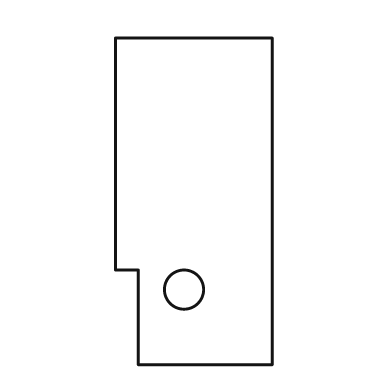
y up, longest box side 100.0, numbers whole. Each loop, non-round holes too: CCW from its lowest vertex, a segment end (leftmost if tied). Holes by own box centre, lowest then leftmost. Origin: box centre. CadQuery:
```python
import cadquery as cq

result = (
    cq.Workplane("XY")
    .moveTo(-17.0, -50.0)
    .lineTo(24.0, -50.0)
    .lineTo(24.0, 50.0)
    .lineTo(-24.0, 50.0)
    .lineTo(-24.0, -21.0)
    .lineTo(-17.0, -21.0)
    .close()
    .moveTo(-3.0, -27.0)
    .circle(6.0)
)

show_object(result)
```